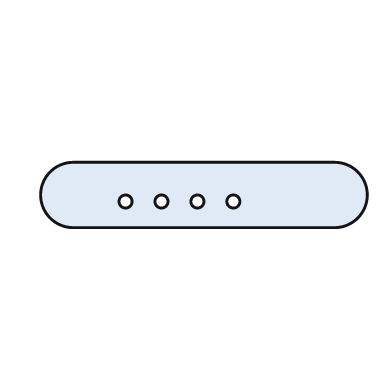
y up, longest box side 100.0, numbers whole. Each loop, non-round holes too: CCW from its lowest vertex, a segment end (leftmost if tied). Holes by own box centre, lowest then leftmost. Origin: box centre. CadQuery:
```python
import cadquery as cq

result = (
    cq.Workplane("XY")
    .moveTo(-40.0, -10.0)
    .lineTo(40.0, -10.0)
    .threePointArc((50.0, 0.0), (40.0, 10.0))
    .lineTo(-40.0, 10.0)
    .threePointArc((-50.0, 0.0), (-40.0, -10.0))
    .close()
    .moveTo(-24.0, -2.0)
    .circle(2.0)
    .moveTo(-13.0, -2.0)
    .circle(2.0)
    .moveTo(-2.0, -2.0)
    .circle(2.0)
    .moveTo(9.0, -2.0)
    .circle(2.0)
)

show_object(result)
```